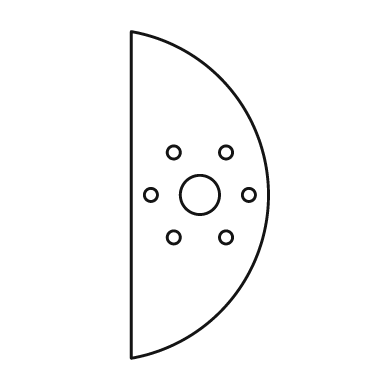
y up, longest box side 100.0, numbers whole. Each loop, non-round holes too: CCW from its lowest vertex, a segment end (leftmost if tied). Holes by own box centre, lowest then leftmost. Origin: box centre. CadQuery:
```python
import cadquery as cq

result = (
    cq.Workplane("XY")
    .moveTo(-21.0, -50.0)
    .threePointArc((21.0, 0.0), (-21.0, 50.0))
    .close()
    .moveTo(-8.0, -13.0)
    .circle(2.0)
    .moveTo(8.0, -13.0)
    .circle(2.0)
    .moveTo(-15.0, 0.0)
    .circle(2.0)
    .moveTo(0.0, 0.0)
    .circle(6.0)
    .moveTo(15.0, 0.0)
    .circle(2.0)
    .moveTo(-8.0, 13.0)
    .circle(2.0)
    .moveTo(8.0, 13.0)
    .circle(2.0)
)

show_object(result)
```